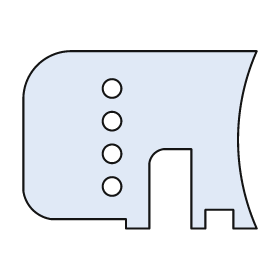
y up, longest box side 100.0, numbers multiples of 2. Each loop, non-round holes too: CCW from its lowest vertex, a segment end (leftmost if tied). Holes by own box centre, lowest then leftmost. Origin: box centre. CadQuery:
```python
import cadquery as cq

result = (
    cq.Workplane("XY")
    .moveTo(-6.0, -38.0)
    .lineTo(4.0, -38.0)
    .lineTo(4.0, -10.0)
    .threePointArc((6.0, -6.0), (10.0, -4.0))
    .lineTo(22.0, -4.0)
    .lineTo(22.0, -38.0)
    .lineTo(28.0, -38.0)
    .lineTo(28.0, -30.0)
    .lineTo(40.0, -30.0)
    .lineTo(40.0, -38.0)
    .lineTo(50.0, -38.0)
    .threePointArc((42.0, 0.0), (50.0, 38.0))
    .lineTo(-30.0, 38.0)
    .threePointArc((-44.0, 32.0), (-50.0, 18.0))
    .lineTo(-50.0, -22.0)
    .threePointArc((-46.0, -30.0), (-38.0, -34.0))
    .lineTo(-6.0, -34.0)
    .close()
    .moveTo(-12.0, -20.0)
    .circle(4.0)
    .moveTo(-12.0, -6.0)
    .circle(4.0)
    .moveTo(-12.0, 8.0)
    .circle(4.0)
    .moveTo(-12.0, 22.0)
    .circle(4.0)
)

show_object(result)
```